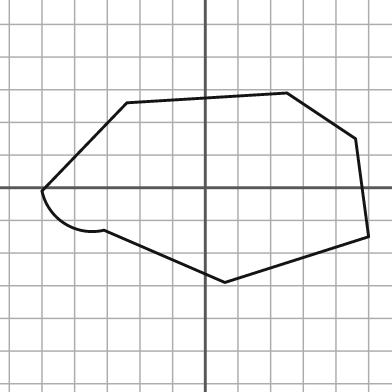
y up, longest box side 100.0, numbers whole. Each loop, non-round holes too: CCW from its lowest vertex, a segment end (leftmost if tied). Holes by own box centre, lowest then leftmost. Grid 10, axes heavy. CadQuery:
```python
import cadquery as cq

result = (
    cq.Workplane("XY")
    .moveTo(6.0, -29.0)
    .lineTo(50.0, -15.0)
    .lineTo(46.0, 15.0)
    .lineTo(25.0, 29.0)
    .lineTo(-24.0, 26.0)
    .lineTo(-50.0, -1.0)
    .threePointArc((-43.0, -11.0), (-31.0, -13.0))
    .close()
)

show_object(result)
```